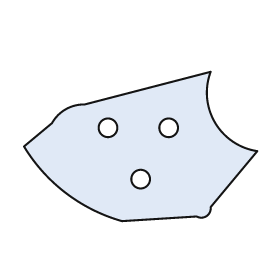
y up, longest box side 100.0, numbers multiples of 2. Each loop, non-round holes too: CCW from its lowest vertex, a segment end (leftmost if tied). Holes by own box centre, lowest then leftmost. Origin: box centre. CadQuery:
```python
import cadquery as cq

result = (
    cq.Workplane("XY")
    .moveTo(-8.0, -32.0)
    .lineTo(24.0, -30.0)
    .threePointArc((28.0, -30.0), (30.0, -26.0))
    .lineTo(50.0, -2.0)
    .threePointArc((32.0, 10.0), (30.0, 32.0))
    .lineTo(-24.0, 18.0)
    .threePointArc((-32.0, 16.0), (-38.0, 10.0))
    .lineTo(-50.0, 0.0)
    .threePointArc((-32.0, -20.0), (-8.0, -32.0))
    .close()
    .moveTo(0.0, -14.0)
    .circle(4.0)
    .moveTo(-14.0, 8.0)
    .circle(4.0)
    .moveTo(12.0, 8.0)
    .circle(4.0)
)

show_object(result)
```